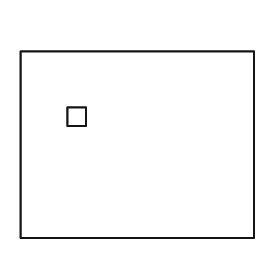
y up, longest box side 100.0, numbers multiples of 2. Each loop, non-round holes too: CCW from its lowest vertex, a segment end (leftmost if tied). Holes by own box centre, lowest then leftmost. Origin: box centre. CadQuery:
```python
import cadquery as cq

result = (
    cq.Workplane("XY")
    .moveTo(-50.0, -40.0)
    .lineTo(50.0, -40.0)
    .lineTo(50.0, 40.0)
    .lineTo(-50.0, 40.0)
    .close()
    .moveTo(-30.0, 8.0)
    .lineTo(-22.0, 8.0)
    .lineTo(-22.0, 16.0)
    .lineTo(-30.0, 16.0)
    .close()
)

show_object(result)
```